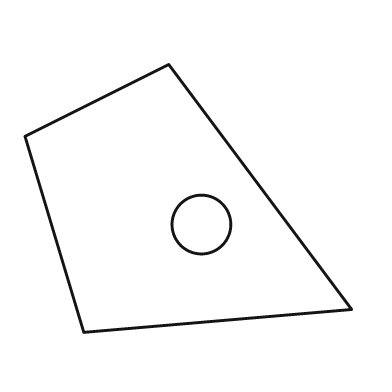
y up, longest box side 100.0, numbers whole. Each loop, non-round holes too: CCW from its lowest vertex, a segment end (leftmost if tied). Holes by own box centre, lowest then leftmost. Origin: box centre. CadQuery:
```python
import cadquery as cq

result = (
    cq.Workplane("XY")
    .moveTo(-32.0, -41.0)
    .lineTo(50.0, -34.0)
    .lineTo(-6.0, 41.0)
    .lineTo(-50.0, 19.0)
    .close()
    .moveTo(4.0, -8.0)
    .circle(9.0)
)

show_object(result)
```